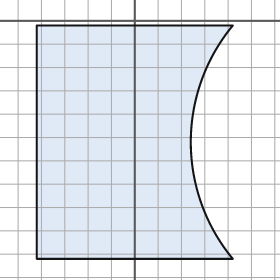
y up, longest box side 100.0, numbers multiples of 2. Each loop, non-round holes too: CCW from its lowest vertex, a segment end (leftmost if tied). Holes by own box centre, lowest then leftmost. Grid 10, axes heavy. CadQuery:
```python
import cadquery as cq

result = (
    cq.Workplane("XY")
    .moveTo(-42.0, -102.0)
    .lineTo(42.0, -102.0)
    .threePointArc((24.0, -52.0), (42.0, -2.0))
    .lineTo(-42.0, -2.0)
    .close()
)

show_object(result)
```